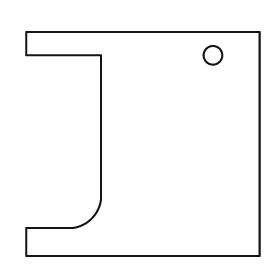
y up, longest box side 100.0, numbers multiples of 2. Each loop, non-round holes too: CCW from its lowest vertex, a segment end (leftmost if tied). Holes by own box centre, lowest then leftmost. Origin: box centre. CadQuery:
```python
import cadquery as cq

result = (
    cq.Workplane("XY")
    .moveTo(-50.0, -48.0)
    .lineTo(50.0, -48.0)
    .lineTo(50.0, 48.0)
    .lineTo(-50.0, 48.0)
    .lineTo(-50.0, 38.0)
    .lineTo(-18.0, 38.0)
    .lineTo(-18.0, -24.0)
    .threePointArc((-22.0, -32.0), (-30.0, -36.0))
    .lineTo(-50.0, -36.0)
    .close()
    .moveTo(30.0, 38.0)
    .circle(4.0)
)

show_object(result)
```